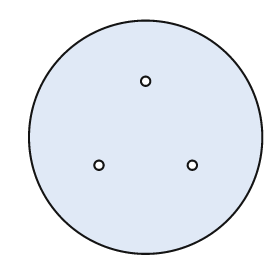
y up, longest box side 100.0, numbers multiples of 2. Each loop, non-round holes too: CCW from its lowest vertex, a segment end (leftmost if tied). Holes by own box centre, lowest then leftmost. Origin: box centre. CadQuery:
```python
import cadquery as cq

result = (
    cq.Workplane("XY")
    .moveTo(0.0, 0.0)
    .circle(50.0)
    .moveTo(-20.0, -12.0)
    .circle(2.0)
    .moveTo(20.0, -12.0)
    .circle(2.0)
    .moveTo(0.0, 24.0)
    .circle(2.0)
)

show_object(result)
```